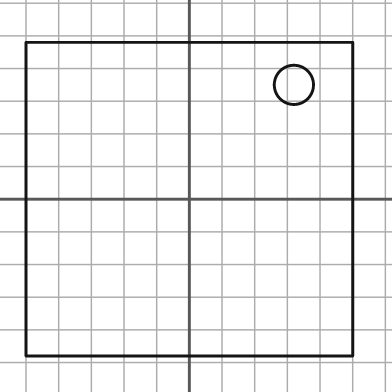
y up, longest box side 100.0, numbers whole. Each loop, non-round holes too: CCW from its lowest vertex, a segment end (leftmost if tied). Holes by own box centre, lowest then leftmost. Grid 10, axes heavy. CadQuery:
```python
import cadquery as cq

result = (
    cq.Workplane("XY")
    .moveTo(-50.0, -48.0)
    .lineTo(50.0, -48.0)
    .lineTo(50.0, 48.0)
    .lineTo(-50.0, 48.0)
    .close()
    .moveTo(32.0, 35.0)
    .circle(6.0)
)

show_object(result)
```